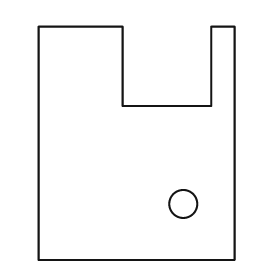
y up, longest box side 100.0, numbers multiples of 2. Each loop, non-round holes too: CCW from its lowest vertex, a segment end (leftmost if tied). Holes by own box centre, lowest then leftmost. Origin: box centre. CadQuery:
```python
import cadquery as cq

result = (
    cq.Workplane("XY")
    .moveTo(-42.0, -50.0)
    .lineTo(42.0, -50.0)
    .lineTo(42.0, 50.0)
    .lineTo(32.0, 50.0)
    .lineTo(32.0, 16.0)
    .lineTo(-6.0, 16.0)
    .lineTo(-6.0, 50.0)
    .lineTo(-42.0, 50.0)
    .close()
    .moveTo(20.0, -26.0)
    .circle(6.0)
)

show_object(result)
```